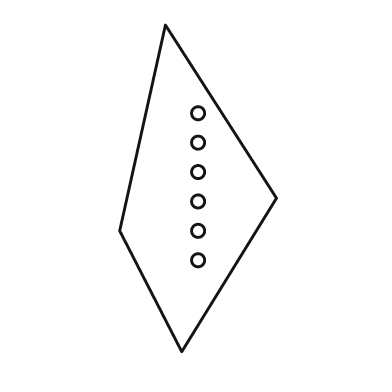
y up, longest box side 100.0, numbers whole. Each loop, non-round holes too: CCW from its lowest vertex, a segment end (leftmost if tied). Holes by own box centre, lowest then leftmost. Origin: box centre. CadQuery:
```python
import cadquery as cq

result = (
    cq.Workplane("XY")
    .moveTo(-5.0, -50.0)
    .lineTo(24.0, -3.0)
    .lineTo(-10.0, 50.0)
    .lineTo(-24.0, -13.0)
    .close()
    .moveTo(0.0, -22.0)
    .circle(2.0)
    .moveTo(0.0, -13.0)
    .circle(2.0)
    .moveTo(0.0, -4.0)
    .circle(2.0)
    .moveTo(0.0, 5.0)
    .circle(2.0)
    .moveTo(0.0, 14.0)
    .circle(2.0)
    .moveTo(0.0, 23.0)
    .circle(2.0)
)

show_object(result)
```